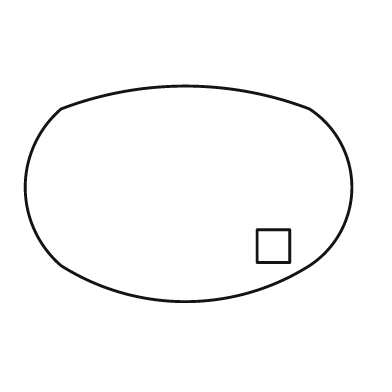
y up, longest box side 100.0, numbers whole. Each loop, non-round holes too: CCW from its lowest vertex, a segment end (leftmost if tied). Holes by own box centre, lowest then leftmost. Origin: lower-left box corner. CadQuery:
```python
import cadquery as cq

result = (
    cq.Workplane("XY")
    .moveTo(11.0, 11.0)
    .threePointArc((49.0, 0.0), (87.0, 11.0))
    .threePointArc((100.0, 35.0), (87.0, 59.0))
    .threePointArc((49.0, 66.0), (11.0, 59.0))
    .threePointArc((0.0, 35.0), (11.0, 11.0))
    .close()
    .moveTo(71.0, 12.0)
    .lineTo(81.0, 12.0)
    .lineTo(81.0, 22.0)
    .lineTo(71.0, 22.0)
    .close()
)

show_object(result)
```